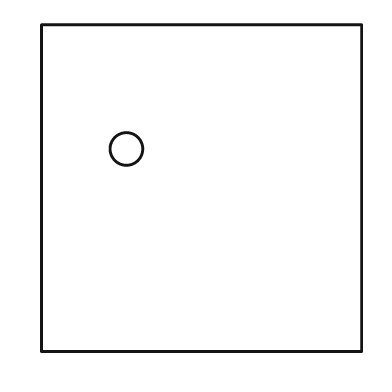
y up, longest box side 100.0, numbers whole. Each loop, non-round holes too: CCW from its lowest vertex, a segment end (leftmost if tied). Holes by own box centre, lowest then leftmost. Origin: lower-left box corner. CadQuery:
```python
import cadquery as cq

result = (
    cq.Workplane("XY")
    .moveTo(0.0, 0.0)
    .lineTo(98.0, 0.0)
    .lineTo(98.0, 100.0)
    .lineTo(0.0, 100.0)
    .close()
    .moveTo(26.0, 62.0)
    .circle(5.0)
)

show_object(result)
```